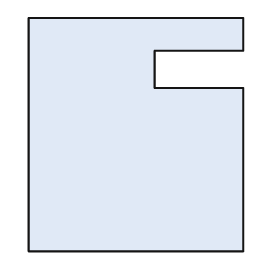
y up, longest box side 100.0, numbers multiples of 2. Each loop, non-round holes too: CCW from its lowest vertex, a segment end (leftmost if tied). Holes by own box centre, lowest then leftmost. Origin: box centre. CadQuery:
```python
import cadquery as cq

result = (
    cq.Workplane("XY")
    .moveTo(-46.0, -50.0)
    .lineTo(46.0, -50.0)
    .lineTo(46.0, 20.0)
    .lineTo(8.0, 20.0)
    .lineTo(8.0, 36.0)
    .lineTo(46.0, 36.0)
    .lineTo(46.0, 50.0)
    .lineTo(-46.0, 50.0)
    .close()
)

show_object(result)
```